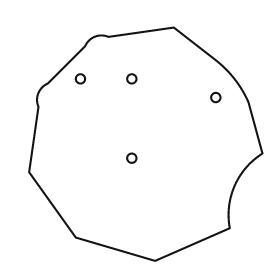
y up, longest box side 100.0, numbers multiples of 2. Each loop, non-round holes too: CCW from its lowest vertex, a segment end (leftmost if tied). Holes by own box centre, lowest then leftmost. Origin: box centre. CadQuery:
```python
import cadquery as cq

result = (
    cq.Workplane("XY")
    .moveTo(4.0, -50.0)
    .lineTo(36.0, -36.0)
    .threePointArc((38.0, -18.0), (50.0, -4.0))
    .lineTo(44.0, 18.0)
    .threePointArc((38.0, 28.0), (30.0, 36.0))
    .lineTo(12.0, 50.0)
    .lineTo(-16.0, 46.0)
    .threePointArc((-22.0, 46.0), (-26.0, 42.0))
    .lineTo(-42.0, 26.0)
    .threePointArc((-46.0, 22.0), (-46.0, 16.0))
    .lineTo(-50.0, -12.0)
    .lineTo(-30.0, -40.0)
    .close()
    .moveTo(-6.0, -6.0)
    .circle(2.0)
    .moveTo(30.0, 20.0)
    .circle(2.0)
    .moveTo(-28.0, 28.0)
    .circle(2.0)
    .moveTo(-6.0, 28.0)
    .circle(2.0)
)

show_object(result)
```